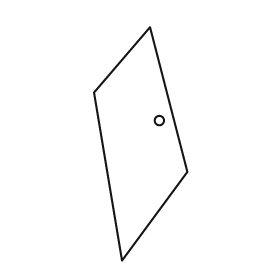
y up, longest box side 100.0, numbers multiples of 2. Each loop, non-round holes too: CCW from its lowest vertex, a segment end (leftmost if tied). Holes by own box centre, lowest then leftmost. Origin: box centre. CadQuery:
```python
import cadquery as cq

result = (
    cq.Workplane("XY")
    .moveTo(-8.0, -50.0)
    .lineTo(20.0, -12.0)
    .lineTo(4.0, 50.0)
    .lineTo(-20.0, 22.0)
    .close()
    .moveTo(8.0, 10.0)
    .circle(2.0)
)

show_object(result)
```